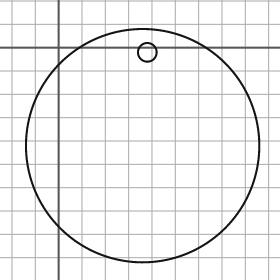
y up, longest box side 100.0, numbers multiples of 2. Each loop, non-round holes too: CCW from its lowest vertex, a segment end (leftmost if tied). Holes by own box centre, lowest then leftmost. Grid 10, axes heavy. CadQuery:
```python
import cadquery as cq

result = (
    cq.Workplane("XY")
    .moveTo(36.0, -42.0)
    .circle(50.0)
    .moveTo(38.0, -2.0)
    .circle(4.0)
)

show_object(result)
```